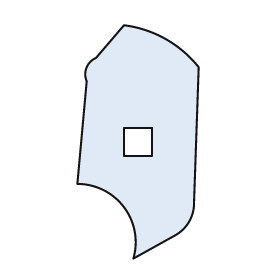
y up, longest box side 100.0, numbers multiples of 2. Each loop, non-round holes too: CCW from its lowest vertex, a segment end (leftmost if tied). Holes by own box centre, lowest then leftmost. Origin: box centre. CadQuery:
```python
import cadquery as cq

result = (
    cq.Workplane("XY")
    .moveTo(-2.0, -50.0)
    .lineTo(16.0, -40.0)
    .threePointArc((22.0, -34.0), (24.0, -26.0))
    .lineTo(26.0, 32.0)
    .threePointArc((12.0, 44.0), (-6.0, 50.0))
    .lineTo(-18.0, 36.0)
    .threePointArc((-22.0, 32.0), (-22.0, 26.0))
    .lineTo(-26.0, -18.0)
    .threePointArc((-6.0, -28.0), (-2.0, -50.0))
    .close()
    .moveTo(-6.0, -6.0)
    .lineTo(6.0, -6.0)
    .lineTo(6.0, 6.0)
    .lineTo(-6.0, 6.0)
    .close()
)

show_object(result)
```